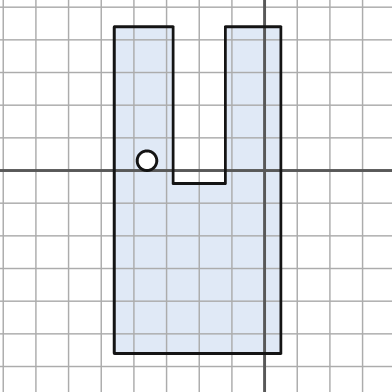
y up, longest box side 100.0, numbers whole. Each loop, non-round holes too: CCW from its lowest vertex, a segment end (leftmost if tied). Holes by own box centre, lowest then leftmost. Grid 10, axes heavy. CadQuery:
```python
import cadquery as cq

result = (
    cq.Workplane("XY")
    .moveTo(-46.0, -56.0)
    .lineTo(5.0, -56.0)
    .lineTo(5.0, 44.0)
    .lineTo(-12.0, 44.0)
    .lineTo(-12.0, -4.0)
    .lineTo(-28.0, -4.0)
    .lineTo(-28.0, 44.0)
    .lineTo(-46.0, 44.0)
    .close()
    .moveTo(-36.0, 3.0)
    .circle(3.0)
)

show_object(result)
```